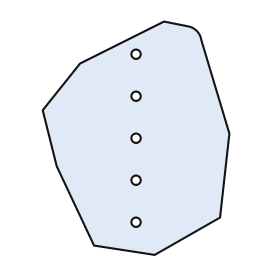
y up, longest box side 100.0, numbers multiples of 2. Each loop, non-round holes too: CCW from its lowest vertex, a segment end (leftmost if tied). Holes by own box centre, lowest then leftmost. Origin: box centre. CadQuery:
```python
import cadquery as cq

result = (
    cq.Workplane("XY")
    .moveTo(8.0, -50.0)
    .lineTo(36.0, -34.0)
    .lineTo(40.0, 2.0)
    .lineTo(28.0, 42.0)
    .threePointArc((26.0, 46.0), (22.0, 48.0))
    .lineTo(12.0, 50.0)
    .lineTo(-24.0, 32.0)
    .lineTo(-40.0, 12.0)
    .lineTo(-34.0, -12.0)
    .lineTo(-18.0, -46.0)
    .close()
    .moveTo(0.0, -36.0)
    .circle(2.0)
    .moveTo(0.0, -18.0)
    .circle(2.0)
    .moveTo(0.0, 0.0)
    .circle(2.0)
    .moveTo(0.0, 18.0)
    .circle(2.0)
    .moveTo(0.0, 36.0)
    .circle(2.0)
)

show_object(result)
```